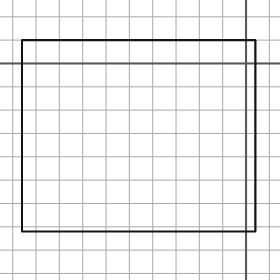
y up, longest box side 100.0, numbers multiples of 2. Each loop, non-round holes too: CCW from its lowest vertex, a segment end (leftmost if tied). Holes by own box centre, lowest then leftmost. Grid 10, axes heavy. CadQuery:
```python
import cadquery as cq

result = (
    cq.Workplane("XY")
    .moveTo(-96.0, -72.0)
    .lineTo(4.0, -72.0)
    .lineTo(4.0, 10.0)
    .lineTo(-96.0, 10.0)
    .close()
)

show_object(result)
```